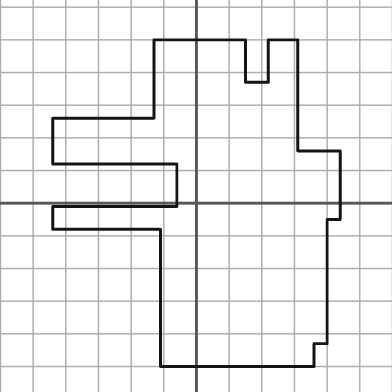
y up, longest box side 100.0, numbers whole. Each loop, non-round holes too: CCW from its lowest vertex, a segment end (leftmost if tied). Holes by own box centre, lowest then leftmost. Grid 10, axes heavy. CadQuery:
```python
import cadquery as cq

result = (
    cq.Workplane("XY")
    .moveTo(-11.0, -50.0)
    .lineTo(36.0, -50.0)
    .lineTo(36.0, -43.0)
    .lineTo(40.0, -43.0)
    .lineTo(40.0, -5.0)
    .lineTo(44.0, -5.0)
    .lineTo(44.0, 16.0)
    .lineTo(31.0, 16.0)
    .lineTo(31.0, 50.0)
    .lineTo(22.0, 50.0)
    .lineTo(22.0, 37.0)
    .lineTo(15.0, 37.0)
    .lineTo(15.0, 50.0)
    .lineTo(-13.0, 50.0)
    .lineTo(-13.0, 26.0)
    .lineTo(-44.0, 26.0)
    .lineTo(-44.0, 12.0)
    .lineTo(-6.0, 12.0)
    .lineTo(-6.0, -1.0)
    .lineTo(-44.0, -1.0)
    .lineTo(-44.0, -8.0)
    .lineTo(-11.0, -8.0)
    .close()
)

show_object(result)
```